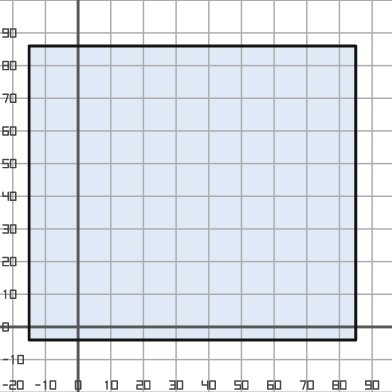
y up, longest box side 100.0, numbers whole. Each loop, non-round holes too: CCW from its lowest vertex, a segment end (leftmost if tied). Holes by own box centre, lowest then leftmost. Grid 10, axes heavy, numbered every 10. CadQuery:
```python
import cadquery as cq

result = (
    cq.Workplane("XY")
    .moveTo(-15.0, -4.0)
    .lineTo(85.0, -4.0)
    .lineTo(85.0, 86.0)
    .lineTo(-15.0, 86.0)
    .close()
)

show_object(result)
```